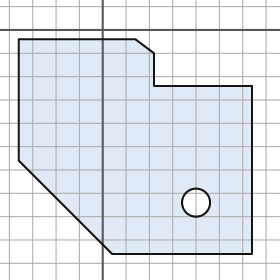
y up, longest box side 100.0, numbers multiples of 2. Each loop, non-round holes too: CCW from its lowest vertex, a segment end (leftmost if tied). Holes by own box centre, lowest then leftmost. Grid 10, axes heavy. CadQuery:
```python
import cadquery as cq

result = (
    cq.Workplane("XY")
    .moveTo(4.0, -96.0)
    .lineTo(64.0, -96.0)
    .lineTo(64.0, -24.0)
    .lineTo(22.0, -24.0)
    .lineTo(22.0, -10.0)
    .lineTo(14.0, -4.0)
    .lineTo(-36.0, -4.0)
    .lineTo(-36.0, -56.0)
    .close()
    .moveTo(40.0, -74.0)
    .circle(6.0)
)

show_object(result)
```